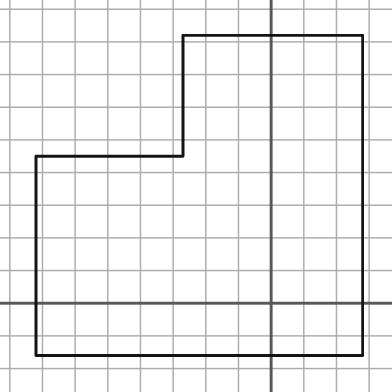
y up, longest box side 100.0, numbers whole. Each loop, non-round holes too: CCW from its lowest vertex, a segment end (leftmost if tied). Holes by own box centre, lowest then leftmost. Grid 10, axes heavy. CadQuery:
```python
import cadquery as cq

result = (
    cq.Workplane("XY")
    .moveTo(-72.0, -16.0)
    .lineTo(28.0, -16.0)
    .lineTo(28.0, 82.0)
    .lineTo(-27.0, 82.0)
    .lineTo(-27.0, 45.0)
    .lineTo(-72.0, 45.0)
    .close()
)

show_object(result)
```